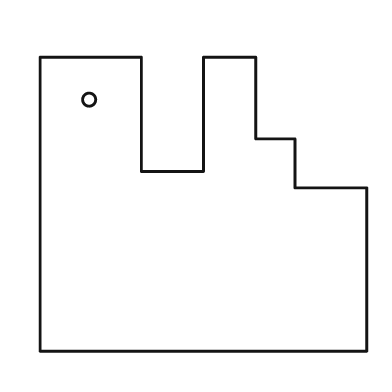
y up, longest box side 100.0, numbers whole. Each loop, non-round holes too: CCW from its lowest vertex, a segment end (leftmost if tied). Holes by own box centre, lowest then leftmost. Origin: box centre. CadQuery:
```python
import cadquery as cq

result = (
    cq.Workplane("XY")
    .moveTo(-50.0, -45.0)
    .lineTo(50.0, -45.0)
    .lineTo(50.0, 5.0)
    .lineTo(28.0, 5.0)
    .lineTo(28.0, 20.0)
    .lineTo(16.0, 20.0)
    .lineTo(16.0, 45.0)
    .lineTo(0.0, 45.0)
    .lineTo(0.0, 10.0)
    .lineTo(-19.0, 10.0)
    .lineTo(-19.0, 45.0)
    .lineTo(-50.0, 45.0)
    .close()
    .moveTo(-35.0, 32.0)
    .circle(2.0)
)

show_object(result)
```